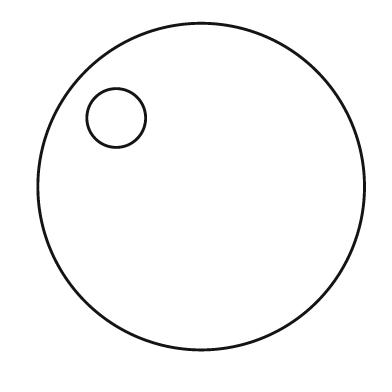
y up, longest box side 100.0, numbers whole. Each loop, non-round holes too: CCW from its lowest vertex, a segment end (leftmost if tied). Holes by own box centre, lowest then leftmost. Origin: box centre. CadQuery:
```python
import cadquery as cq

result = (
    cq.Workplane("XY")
    .moveTo(0.0, 0.0)
    .circle(50.0)
    .moveTo(-26.0, 21.0)
    .circle(9.0)
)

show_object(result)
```